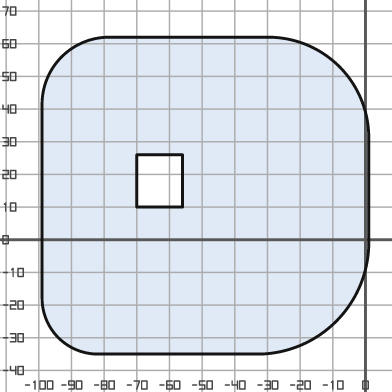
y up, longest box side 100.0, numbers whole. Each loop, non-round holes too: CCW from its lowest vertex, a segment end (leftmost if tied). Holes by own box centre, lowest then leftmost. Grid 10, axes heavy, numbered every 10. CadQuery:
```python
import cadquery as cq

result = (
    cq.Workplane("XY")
    .moveTo(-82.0, -35.0)
    .lineTo(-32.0, -35.0)
    .threePointArc((-9.0, -25.0), (1.0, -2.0))
    .lineTo(1.0, 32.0)
    .threePointArc((-8.0, 53.0), (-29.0, 62.0))
    .lineTo(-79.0, 62.0)
    .threePointArc((-93.0, 56.0), (-99.0, 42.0))
    .lineTo(-99.0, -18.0)
    .threePointArc((-94.0, -30.0), (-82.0, -35.0))
    .close()
    .moveTo(-70.0, 10.0)
    .lineTo(-56.0, 10.0)
    .lineTo(-56.0, 26.0)
    .lineTo(-70.0, 26.0)
    .close()
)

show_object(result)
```